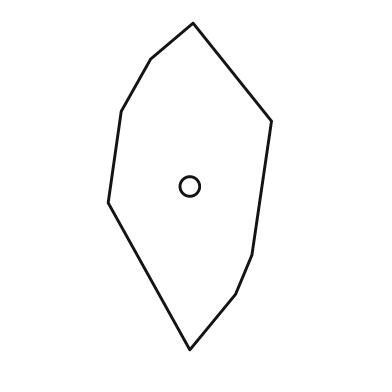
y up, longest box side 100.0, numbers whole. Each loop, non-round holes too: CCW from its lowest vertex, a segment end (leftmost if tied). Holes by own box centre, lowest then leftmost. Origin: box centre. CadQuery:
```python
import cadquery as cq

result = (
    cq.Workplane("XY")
    .moveTo(0.0, -50.0)
    .lineTo(14.0, -33.0)
    .lineTo(19.0, -21.0)
    .lineTo(25.0, 20.0)
    .lineTo(1.0, 50.0)
    .lineTo(-12.0, 39.0)
    .lineTo(-21.0, 23.0)
    .lineTo(-25.0, -5.0)
    .close()
    .moveTo(0.0, 0.0)
    .circle(3.0)
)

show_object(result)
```